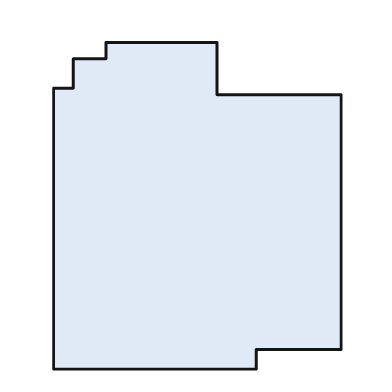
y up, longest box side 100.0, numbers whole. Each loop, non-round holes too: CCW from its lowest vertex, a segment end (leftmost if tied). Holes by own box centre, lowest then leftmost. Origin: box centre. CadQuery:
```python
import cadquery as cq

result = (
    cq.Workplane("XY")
    .moveTo(-44.0, -50.0)
    .lineTo(18.0, -50.0)
    .lineTo(18.0, -44.0)
    .lineTo(44.0, -44.0)
    .lineTo(44.0, 34.0)
    .lineTo(6.0, 34.0)
    .lineTo(6.0, 50.0)
    .lineTo(-28.0, 50.0)
    .lineTo(-28.0, 45.0)
    .lineTo(-38.0, 45.0)
    .lineTo(-38.0, 36.0)
    .lineTo(-44.0, 36.0)
    .close()
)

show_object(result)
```